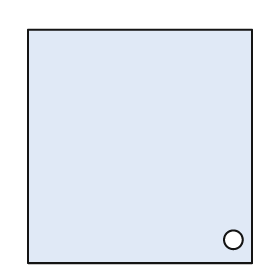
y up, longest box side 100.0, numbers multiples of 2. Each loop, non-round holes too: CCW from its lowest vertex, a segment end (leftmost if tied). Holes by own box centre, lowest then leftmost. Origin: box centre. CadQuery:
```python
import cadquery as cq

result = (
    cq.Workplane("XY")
    .moveTo(-48.0, -50.0)
    .lineTo(48.0, -50.0)
    .lineTo(48.0, 50.0)
    .lineTo(-48.0, 50.0)
    .close()
    .moveTo(40.0, -40.0)
    .circle(4.0)
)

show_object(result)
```